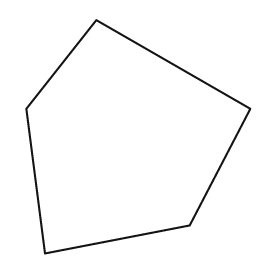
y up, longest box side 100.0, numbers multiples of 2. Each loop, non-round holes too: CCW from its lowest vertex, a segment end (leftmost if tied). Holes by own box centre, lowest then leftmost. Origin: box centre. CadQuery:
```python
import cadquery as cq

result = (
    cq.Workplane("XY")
    .moveTo(-40.0, -50.0)
    .lineTo(22.0, -38.0)
    .lineTo(48.0, 12.0)
    .lineTo(-18.0, 50.0)
    .lineTo(-48.0, 12.0)
    .close()
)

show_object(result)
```